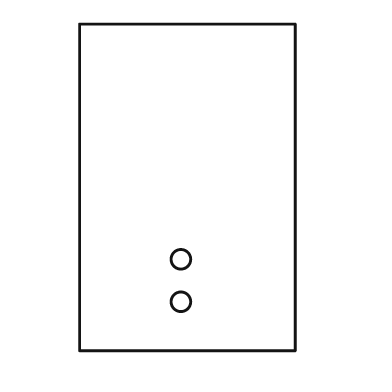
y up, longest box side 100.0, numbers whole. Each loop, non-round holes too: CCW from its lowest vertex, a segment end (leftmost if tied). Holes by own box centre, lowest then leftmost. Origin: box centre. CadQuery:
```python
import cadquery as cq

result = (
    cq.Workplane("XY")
    .moveTo(-33.0, -50.0)
    .lineTo(33.0, -50.0)
    .lineTo(33.0, 50.0)
    .lineTo(-33.0, 50.0)
    .close()
    .moveTo(-2.0, -35.0)
    .circle(3.0)
    .moveTo(-2.0, -22.0)
    .circle(3.0)
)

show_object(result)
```